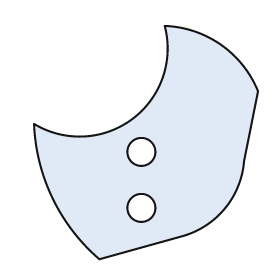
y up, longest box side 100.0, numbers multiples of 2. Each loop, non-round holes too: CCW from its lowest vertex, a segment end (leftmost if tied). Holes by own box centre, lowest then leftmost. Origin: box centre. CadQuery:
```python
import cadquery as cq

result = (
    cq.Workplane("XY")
    .moveTo(-20.0, -50.0)
    .lineTo(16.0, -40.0)
    .threePointArc((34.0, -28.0), (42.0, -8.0))
    .lineTo(48.0, 22.0)
    .threePointArc((32.0, 42.0), (8.0, 50.0))
    .threePointArc((-6.0, 10.0), (-48.0, 8.0))
    .threePointArc((-40.0, -24.0), (-20.0, -50.0))
    .close()
    .moveTo(-2.0, -28.0)
    .circle(6.0)
    .moveTo(-2.0, -4.0)
    .circle(6.0)
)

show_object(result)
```